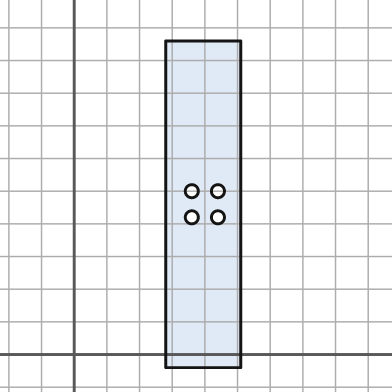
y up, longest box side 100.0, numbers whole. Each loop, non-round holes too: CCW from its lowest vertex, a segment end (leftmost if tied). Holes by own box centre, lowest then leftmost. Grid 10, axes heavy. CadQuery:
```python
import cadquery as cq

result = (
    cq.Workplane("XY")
    .moveTo(28.0, -4.0)
    .lineTo(51.0, -4.0)
    .lineTo(51.0, 96.0)
    .lineTo(28.0, 96.0)
    .close()
    .moveTo(36.0, 42.0)
    .circle(2.0)
    .moveTo(44.0, 42.0)
    .circle(2.0)
    .moveTo(36.0, 50.0)
    .circle(2.0)
    .moveTo(44.0, 50.0)
    .circle(2.0)
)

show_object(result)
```